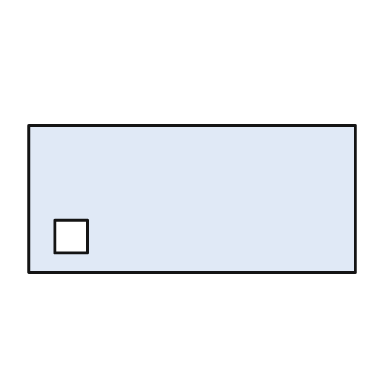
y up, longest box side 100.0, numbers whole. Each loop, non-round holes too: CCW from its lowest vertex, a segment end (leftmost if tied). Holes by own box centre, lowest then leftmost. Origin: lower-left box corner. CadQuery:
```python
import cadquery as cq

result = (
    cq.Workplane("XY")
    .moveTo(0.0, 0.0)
    .lineTo(100.0, 0.0)
    .lineTo(100.0, 45.0)
    .lineTo(0.0, 45.0)
    .close()
    .moveTo(8.0, 6.0)
    .lineTo(18.0, 6.0)
    .lineTo(18.0, 16.0)
    .lineTo(8.0, 16.0)
    .close()
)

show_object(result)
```